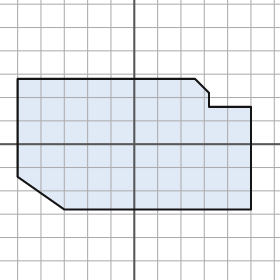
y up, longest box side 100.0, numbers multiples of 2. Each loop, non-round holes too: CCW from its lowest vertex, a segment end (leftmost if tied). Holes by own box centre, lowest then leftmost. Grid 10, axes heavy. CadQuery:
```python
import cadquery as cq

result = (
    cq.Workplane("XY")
    .moveTo(-30.0, -28.0)
    .lineTo(50.0, -28.0)
    .lineTo(50.0, 16.0)
    .lineTo(32.0, 16.0)
    .lineTo(32.0, 22.0)
    .lineTo(26.0, 28.0)
    .lineTo(-50.0, 28.0)
    .lineTo(-50.0, -14.0)
    .close()
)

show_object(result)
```